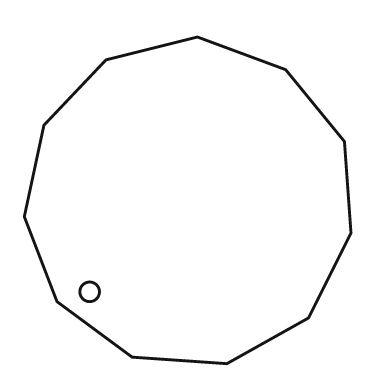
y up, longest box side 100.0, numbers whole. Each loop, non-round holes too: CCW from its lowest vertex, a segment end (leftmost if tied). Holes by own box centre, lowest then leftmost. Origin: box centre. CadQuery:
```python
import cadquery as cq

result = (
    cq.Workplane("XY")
    .moveTo(12.0, -50.0)
    .lineTo(37.0, -36.0)
    .lineTo(50.0, -10.0)
    .lineTo(48.0, 18.0)
    .lineTo(30.0, 40.0)
    .lineTo(3.0, 50.0)
    .lineTo(-25.0, 43.0)
    .lineTo(-44.0, 23.0)
    .lineTo(-50.0, -5.0)
    .lineTo(-40.0, -31.0)
    .lineTo(-17.0, -48.0)
    .close()
    .moveTo(-30.0, -28.0)
    .circle(3.0)
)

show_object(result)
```